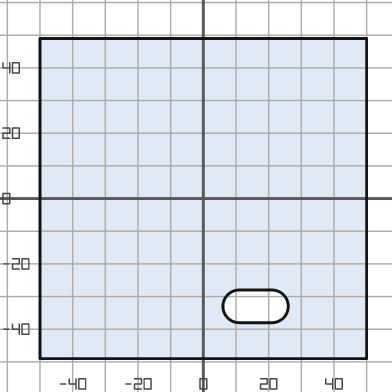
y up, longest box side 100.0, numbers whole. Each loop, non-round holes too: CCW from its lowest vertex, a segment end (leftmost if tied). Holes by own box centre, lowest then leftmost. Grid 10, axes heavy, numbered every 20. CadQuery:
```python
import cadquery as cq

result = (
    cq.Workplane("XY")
    .moveTo(-50.0, -49.0)
    .lineTo(50.0, -49.0)
    .lineTo(50.0, 49.0)
    .lineTo(-50.0, 49.0)
    .close()
    .moveTo(11.0, -38.0)
    .lineTo(21.0, -38.0)
    .threePointArc((26.0, -33.0), (21.0, -28.0))
    .lineTo(11.0, -28.0)
    .threePointArc((6.0, -33.0), (11.0, -38.0))
    .close()
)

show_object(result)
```